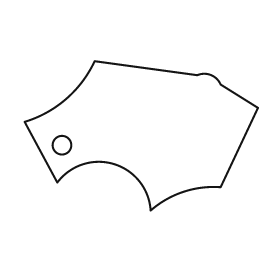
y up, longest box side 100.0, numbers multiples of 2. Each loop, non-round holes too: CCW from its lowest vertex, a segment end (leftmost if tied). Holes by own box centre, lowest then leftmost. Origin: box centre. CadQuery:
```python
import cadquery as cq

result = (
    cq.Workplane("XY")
    .moveTo(4.0, -32.0)
    .threePointArc((18.0, -24.0), (34.0, -22.0))
    .lineTo(50.0, 12.0)
    .lineTo(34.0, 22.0)
    .threePointArc((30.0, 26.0), (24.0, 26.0))
    .lineTo(-20.0, 32.0)
    .threePointArc((-32.0, 16.0), (-50.0, 6.0))
    .lineTo(-36.0, -20.0)
    .threePointArc((-12.0, -12.0), (4.0, -32.0))
    .close()
    .moveTo(-34.0, -4.0)
    .circle(4.0)
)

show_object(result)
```